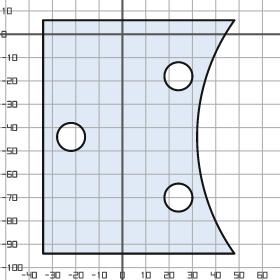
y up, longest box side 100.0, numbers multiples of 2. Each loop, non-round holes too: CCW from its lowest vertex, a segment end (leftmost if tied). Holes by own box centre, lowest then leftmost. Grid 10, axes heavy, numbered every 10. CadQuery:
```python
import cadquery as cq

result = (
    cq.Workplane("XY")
    .moveTo(-34.0, -94.0)
    .lineTo(48.0, -94.0)
    .threePointArc((32.0, -44.0), (48.0, 6.0))
    .lineTo(-34.0, 6.0)
    .close()
    .moveTo(24.0, -70.0)
    .circle(6.0)
    .moveTo(-22.0, -44.0)
    .circle(6.0)
    .moveTo(24.0, -18.0)
    .circle(6.0)
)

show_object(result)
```